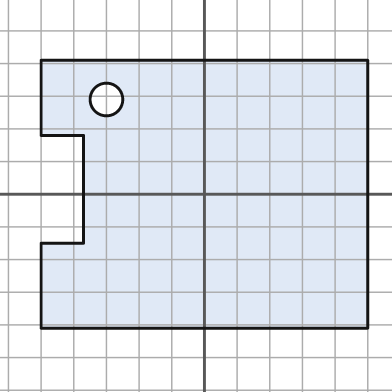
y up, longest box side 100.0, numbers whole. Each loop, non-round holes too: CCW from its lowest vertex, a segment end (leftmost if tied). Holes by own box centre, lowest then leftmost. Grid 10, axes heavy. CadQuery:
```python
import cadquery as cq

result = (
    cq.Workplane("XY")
    .moveTo(-50.0, -41.0)
    .lineTo(50.0, -41.0)
    .lineTo(50.0, 41.0)
    .lineTo(-50.0, 41.0)
    .lineTo(-50.0, 18.0)
    .lineTo(-37.0, 18.0)
    .lineTo(-37.0, -15.0)
    .lineTo(-50.0, -15.0)
    .close()
    .moveTo(-30.0, 29.0)
    .circle(5.0)
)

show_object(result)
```